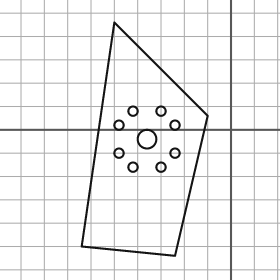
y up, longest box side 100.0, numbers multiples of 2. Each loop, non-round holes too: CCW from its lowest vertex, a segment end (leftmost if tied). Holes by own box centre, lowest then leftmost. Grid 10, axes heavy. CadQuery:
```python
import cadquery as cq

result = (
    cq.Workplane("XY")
    .moveTo(-24.0, -54.0)
    .lineTo(-10.0, 6.0)
    .lineTo(-50.0, 46.0)
    .lineTo(-64.0, -50.0)
    .close()
    .moveTo(-42.0, -16.0)
    .circle(2.0)
    .moveTo(-30.0, -16.0)
    .circle(2.0)
    .moveTo(-48.0, -10.0)
    .circle(2.0)
    .moveTo(-24.0, -10.0)
    .circle(2.0)
    .moveTo(-36.0, -4.0)
    .circle(4.0)
    .moveTo(-48.0, 2.0)
    .circle(2.0)
    .moveTo(-24.0, 2.0)
    .circle(2.0)
    .moveTo(-42.0, 8.0)
    .circle(2.0)
    .moveTo(-30.0, 8.0)
    .circle(2.0)
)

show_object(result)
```